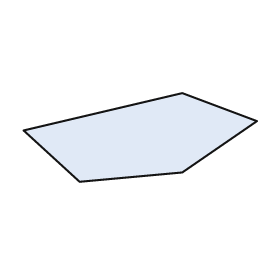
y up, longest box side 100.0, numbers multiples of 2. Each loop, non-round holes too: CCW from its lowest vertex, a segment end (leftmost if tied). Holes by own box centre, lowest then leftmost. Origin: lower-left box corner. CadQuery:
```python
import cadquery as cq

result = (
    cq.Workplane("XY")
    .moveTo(24.0, 0.0)
    .lineTo(68.0, 4.0)
    .lineTo(100.0, 26.0)
    .lineTo(68.0, 38.0)
    .lineTo(0.0, 22.0)
    .close()
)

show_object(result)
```